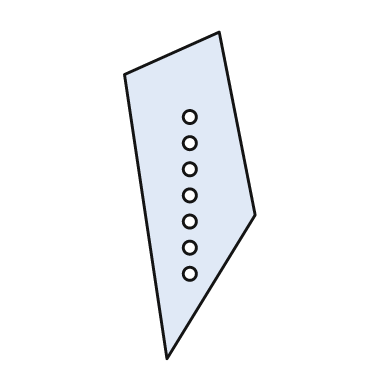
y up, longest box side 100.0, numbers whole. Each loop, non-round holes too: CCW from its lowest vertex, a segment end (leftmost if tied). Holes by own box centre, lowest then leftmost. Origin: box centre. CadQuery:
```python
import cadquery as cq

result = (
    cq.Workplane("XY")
    .moveTo(-7.0, -50.0)
    .lineTo(20.0, -6.0)
    .lineTo(9.0, 50.0)
    .lineTo(-20.0, 37.0)
    .close()
    .moveTo(0.0, -24.0)
    .circle(2.0)
    .moveTo(0.0, -16.0)
    .circle(2.0)
    .moveTo(0.0, -8.0)
    .circle(2.0)
    .moveTo(0.0, 0.0)
    .circle(2.0)
    .moveTo(0.0, 8.0)
    .circle(2.0)
    .moveTo(0.0, 16.0)
    .circle(2.0)
    .moveTo(0.0, 24.0)
    .circle(2.0)
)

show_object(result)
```